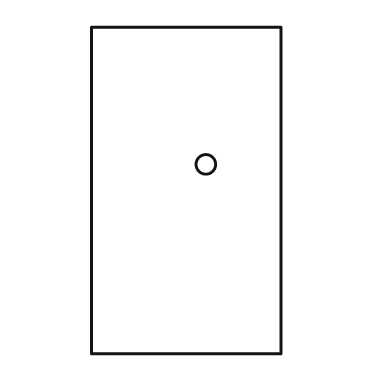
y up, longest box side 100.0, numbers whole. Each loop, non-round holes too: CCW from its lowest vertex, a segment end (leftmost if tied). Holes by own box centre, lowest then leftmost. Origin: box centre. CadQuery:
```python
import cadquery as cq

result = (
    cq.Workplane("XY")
    .moveTo(-29.0, -50.0)
    .lineTo(29.0, -50.0)
    .lineTo(29.0, 50.0)
    .lineTo(-29.0, 50.0)
    .close()
    .moveTo(6.0, 8.0)
    .circle(3.0)
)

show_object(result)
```